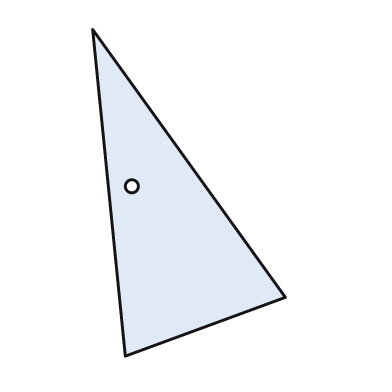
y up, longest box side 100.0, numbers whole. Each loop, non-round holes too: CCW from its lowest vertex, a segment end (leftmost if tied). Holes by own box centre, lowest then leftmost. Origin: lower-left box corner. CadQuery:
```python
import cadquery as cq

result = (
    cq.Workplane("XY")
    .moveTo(10.0, 0.0)
    .lineTo(59.0, 18.0)
    .lineTo(0.0, 100.0)
    .close()
    .moveTo(12.0, 52.0)
    .circle(2.0)
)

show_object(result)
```